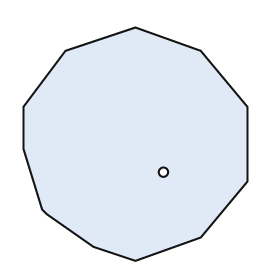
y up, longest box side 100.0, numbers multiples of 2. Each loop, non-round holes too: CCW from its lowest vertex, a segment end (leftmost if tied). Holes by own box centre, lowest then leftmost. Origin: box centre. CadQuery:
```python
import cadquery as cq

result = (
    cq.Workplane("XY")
    .moveTo(0.0, -50.0)
    .lineTo(28.0, -40.0)
    .lineTo(48.0, -16.0)
    .lineTo(48.0, 16.0)
    .lineTo(28.0, 40.0)
    .lineTo(0.0, 50.0)
    .lineTo(-30.0, 40.0)
    .lineTo(-48.0, 16.0)
    .lineTo(-48.0, -2.0)
    .lineTo(-40.0, -28.0)
    .lineTo(-38.0, -30.0)
    .lineTo(-18.0, -44.0)
    .close()
    .moveTo(12.0, -12.0)
    .circle(2.0)
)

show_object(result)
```